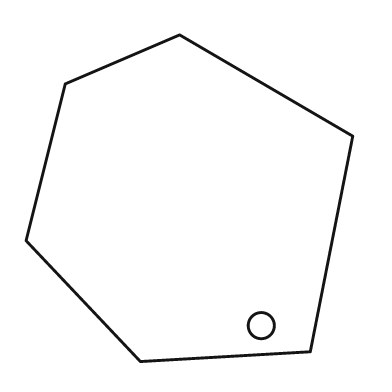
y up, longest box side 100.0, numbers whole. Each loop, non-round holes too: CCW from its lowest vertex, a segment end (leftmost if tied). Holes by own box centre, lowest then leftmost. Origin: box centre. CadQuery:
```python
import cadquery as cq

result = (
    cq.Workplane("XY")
    .moveTo(-15.0, -50.0)
    .lineTo(37.0, -47.0)
    .lineTo(50.0, 19.0)
    .lineTo(-3.0, 50.0)
    .lineTo(-38.0, 35.0)
    .lineTo(-50.0, -13.0)
    .close()
    .moveTo(22.0, -39.0)
    .circle(4.0)
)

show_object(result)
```